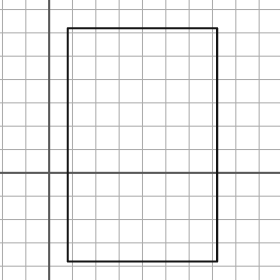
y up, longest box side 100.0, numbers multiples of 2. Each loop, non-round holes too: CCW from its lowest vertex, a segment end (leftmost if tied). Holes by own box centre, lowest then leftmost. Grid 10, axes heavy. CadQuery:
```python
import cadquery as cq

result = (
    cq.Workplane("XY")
    .moveTo(8.0, -38.0)
    .lineTo(72.0, -38.0)
    .lineTo(72.0, 62.0)
    .lineTo(8.0, 62.0)
    .close()
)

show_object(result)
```